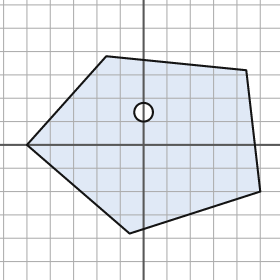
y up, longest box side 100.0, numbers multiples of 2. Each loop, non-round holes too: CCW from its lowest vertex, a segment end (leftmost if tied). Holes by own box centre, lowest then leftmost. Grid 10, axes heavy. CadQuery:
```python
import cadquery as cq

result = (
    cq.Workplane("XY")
    .moveTo(-6.0, -38.0)
    .lineTo(50.0, -20.0)
    .lineTo(44.0, 32.0)
    .lineTo(-16.0, 38.0)
    .lineTo(-50.0, 0.0)
    .close()
    .moveTo(0.0, 14.0)
    .circle(4.0)
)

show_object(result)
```